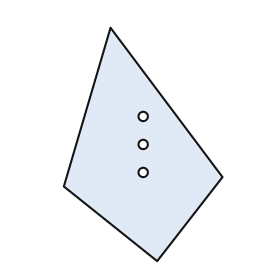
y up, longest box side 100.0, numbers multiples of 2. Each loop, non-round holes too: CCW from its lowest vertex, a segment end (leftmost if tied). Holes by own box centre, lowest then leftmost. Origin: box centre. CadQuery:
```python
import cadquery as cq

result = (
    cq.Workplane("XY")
    .moveTo(6.0, -50.0)
    .lineTo(34.0, -14.0)
    .lineTo(-14.0, 50.0)
    .lineTo(-34.0, -18.0)
    .close()
    .moveTo(0.0, -12.0)
    .circle(2.0)
    .moveTo(0.0, 0.0)
    .circle(2.0)
    .moveTo(0.0, 12.0)
    .circle(2.0)
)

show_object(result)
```